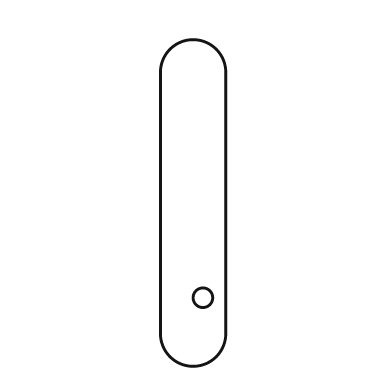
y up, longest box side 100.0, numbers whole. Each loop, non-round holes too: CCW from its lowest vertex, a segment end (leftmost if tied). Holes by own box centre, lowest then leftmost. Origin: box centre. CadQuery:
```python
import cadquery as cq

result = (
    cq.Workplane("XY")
    .moveTo(-10.0, -40.0)
    .threePointArc((0.0, -50.0), (10.0, -40.0))
    .lineTo(10.0, 40.0)
    .threePointArc((0.0, 50.0), (-10.0, 40.0))
    .close()
    .moveTo(3.0, -29.0)
    .circle(3.0)
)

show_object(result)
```